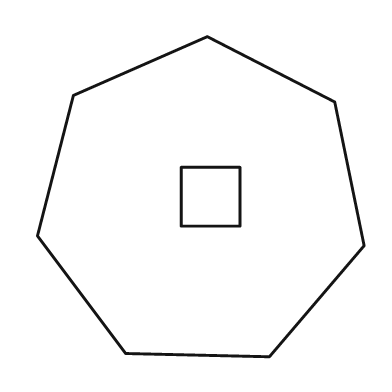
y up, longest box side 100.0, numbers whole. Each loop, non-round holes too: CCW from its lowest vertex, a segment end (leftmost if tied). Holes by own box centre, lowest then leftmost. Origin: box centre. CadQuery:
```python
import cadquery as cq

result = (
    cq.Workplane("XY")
    .moveTo(21.0, -49.0)
    .lineTo(50.0, -15.0)
    .lineTo(41.0, 29.0)
    .lineTo(2.0, 49.0)
    .lineTo(-39.0, 31.0)
    .lineTo(-50.0, -12.0)
    .lineTo(-23.0, -48.0)
    .close()
    .moveTo(-6.0, -9.0)
    .lineTo(12.0, -9.0)
    .lineTo(12.0, 9.0)
    .lineTo(-6.0, 9.0)
    .close()
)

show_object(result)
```